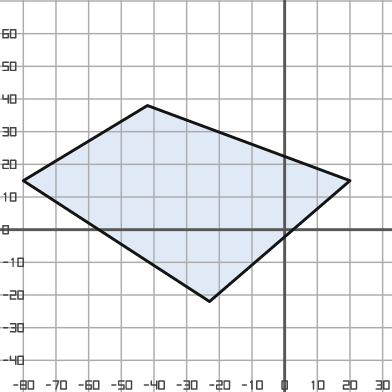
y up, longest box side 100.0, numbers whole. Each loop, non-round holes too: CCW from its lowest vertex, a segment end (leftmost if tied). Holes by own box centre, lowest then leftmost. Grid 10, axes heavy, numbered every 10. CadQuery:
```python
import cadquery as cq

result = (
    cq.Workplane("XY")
    .moveTo(-23.0, -22.0)
    .lineTo(20.0, 15.0)
    .lineTo(-42.0, 38.0)
    .lineTo(-80.0, 15.0)
    .close()
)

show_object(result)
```